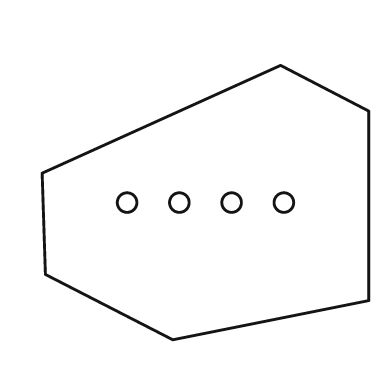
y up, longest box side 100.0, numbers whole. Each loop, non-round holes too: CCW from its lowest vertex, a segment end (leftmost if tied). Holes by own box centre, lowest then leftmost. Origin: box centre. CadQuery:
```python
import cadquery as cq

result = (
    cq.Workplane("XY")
    .moveTo(-10.0, -42.0)
    .lineTo(50.0, -30.0)
    .lineTo(50.0, 28.0)
    .lineTo(23.0, 42.0)
    .lineTo(-50.0, 9.0)
    .lineTo(-49.0, -22.0)
    .close()
    .moveTo(-24.0, 0.0)
    .circle(3.0)
    .moveTo(-8.0, 0.0)
    .circle(3.0)
    .moveTo(8.0, 0.0)
    .circle(3.0)
    .moveTo(24.0, 0.0)
    .circle(3.0)
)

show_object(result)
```